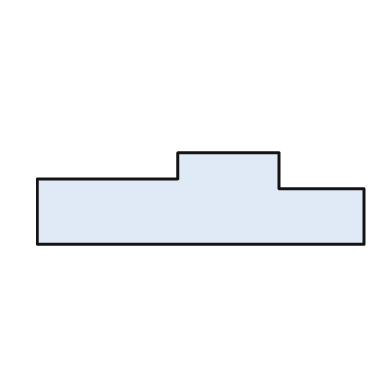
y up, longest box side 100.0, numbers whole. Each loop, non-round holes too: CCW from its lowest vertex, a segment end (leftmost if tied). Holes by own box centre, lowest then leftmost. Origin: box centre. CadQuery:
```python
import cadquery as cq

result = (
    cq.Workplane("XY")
    .moveTo(-50.0, -14.0)
    .lineTo(50.0, -14.0)
    .lineTo(50.0, 3.0)
    .lineTo(24.0, 3.0)
    .lineTo(24.0, 14.0)
    .lineTo(-7.0, 14.0)
    .lineTo(-7.0, 6.0)
    .lineTo(-50.0, 6.0)
    .close()
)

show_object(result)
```